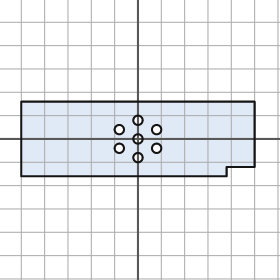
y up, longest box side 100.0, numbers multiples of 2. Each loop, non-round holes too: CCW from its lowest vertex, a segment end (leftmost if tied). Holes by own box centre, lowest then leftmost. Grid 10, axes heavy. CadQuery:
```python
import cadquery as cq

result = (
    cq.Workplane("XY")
    .moveTo(-50.0, -16.0)
    .lineTo(38.0, -16.0)
    .lineTo(38.0, -12.0)
    .lineTo(50.0, -12.0)
    .lineTo(50.0, 16.0)
    .lineTo(-50.0, 16.0)
    .close()
    .moveTo(0.0, -8.0)
    .circle(2.0)
    .moveTo(-8.0, -4.0)
    .circle(2.0)
    .moveTo(8.0, -4.0)
    .circle(2.0)
    .moveTo(0.0, 0.0)
    .circle(2.0)
    .moveTo(-8.0, 4.0)
    .circle(2.0)
    .moveTo(8.0, 4.0)
    .circle(2.0)
    .moveTo(0.0, 8.0)
    .circle(2.0)
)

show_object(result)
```